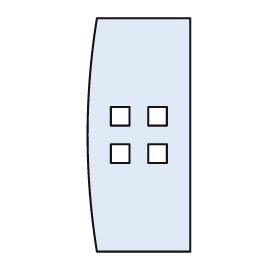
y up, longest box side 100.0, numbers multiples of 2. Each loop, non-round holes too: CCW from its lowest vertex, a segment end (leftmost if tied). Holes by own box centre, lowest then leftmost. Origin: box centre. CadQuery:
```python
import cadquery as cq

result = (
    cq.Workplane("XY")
    .moveTo(-18.0, -50.0)
    .lineTo(22.0, -50.0)
    .lineTo(22.0, 50.0)
    .lineTo(-18.0, 50.0)
    .threePointArc((-22.0, 0.0), (-18.0, -50.0))
    .close()
    .moveTo(-12.0, -12.0)
    .lineTo(-4.0, -12.0)
    .lineTo(-4.0, -4.0)
    .lineTo(-12.0, -4.0)
    .close()
    .moveTo(4.0, -12.0)
    .lineTo(12.0, -12.0)
    .lineTo(12.0, -4.0)
    .lineTo(4.0, -4.0)
    .close()
    .moveTo(-12.0, 4.0)
    .lineTo(-4.0, 4.0)
    .lineTo(-4.0, 12.0)
    .lineTo(-12.0, 12.0)
    .close()
    .moveTo(4.0, 4.0)
    .lineTo(12.0, 4.0)
    .lineTo(12.0, 12.0)
    .lineTo(4.0, 12.0)
    .close()
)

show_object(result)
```